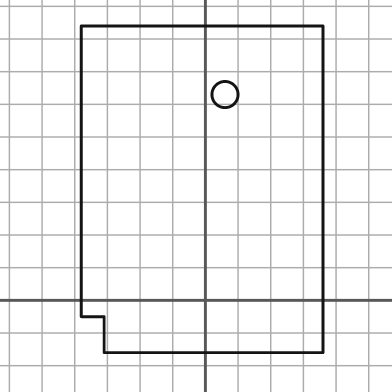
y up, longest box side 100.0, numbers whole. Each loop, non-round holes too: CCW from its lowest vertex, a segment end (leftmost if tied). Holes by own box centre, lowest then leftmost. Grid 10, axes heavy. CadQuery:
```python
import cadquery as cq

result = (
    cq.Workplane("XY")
    .moveTo(-31.0, -16.0)
    .lineTo(36.0, -16.0)
    .lineTo(36.0, 84.0)
    .lineTo(-38.0, 84.0)
    .lineTo(-38.0, -5.0)
    .lineTo(-31.0, -5.0)
    .close()
    .moveTo(6.0, 63.0)
    .circle(4.0)
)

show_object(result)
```